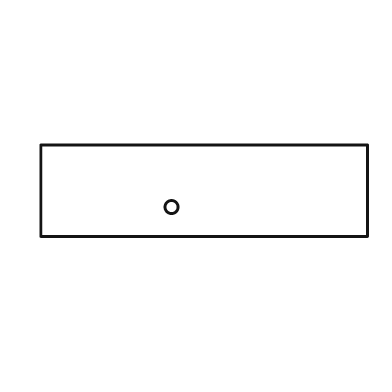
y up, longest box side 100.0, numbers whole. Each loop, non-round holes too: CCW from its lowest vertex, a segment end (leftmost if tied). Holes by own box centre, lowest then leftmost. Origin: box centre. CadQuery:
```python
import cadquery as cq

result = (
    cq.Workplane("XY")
    .moveTo(-50.0, -14.0)
    .lineTo(50.0, -14.0)
    .lineTo(50.0, 14.0)
    .lineTo(-50.0, 14.0)
    .close()
    .moveTo(-10.0, -5.0)
    .circle(2.0)
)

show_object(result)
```